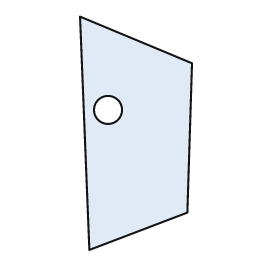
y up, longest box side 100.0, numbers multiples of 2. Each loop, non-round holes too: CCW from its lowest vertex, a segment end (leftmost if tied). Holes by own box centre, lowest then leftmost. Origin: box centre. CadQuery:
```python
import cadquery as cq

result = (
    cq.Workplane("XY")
    .moveTo(-20.0, -50.0)
    .lineTo(22.0, -34.0)
    .lineTo(24.0, 30.0)
    .lineTo(-24.0, 50.0)
    .close()
    .moveTo(-12.0, 10.0)
    .circle(6.0)
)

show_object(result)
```